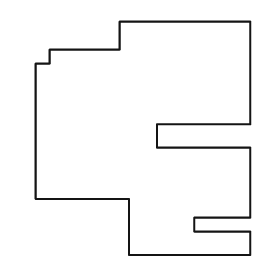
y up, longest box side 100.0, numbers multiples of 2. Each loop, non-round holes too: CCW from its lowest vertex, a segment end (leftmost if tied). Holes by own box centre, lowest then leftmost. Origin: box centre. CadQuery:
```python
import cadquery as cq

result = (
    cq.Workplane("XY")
    .moveTo(-6.0, -50.0)
    .lineTo(46.0, -50.0)
    .lineTo(46.0, -40.0)
    .lineTo(22.0, -40.0)
    .lineTo(22.0, -34.0)
    .lineTo(46.0, -34.0)
    .lineTo(46.0, -4.0)
    .lineTo(6.0, -4.0)
    .lineTo(6.0, 6.0)
    .lineTo(46.0, 6.0)
    .lineTo(46.0, 50.0)
    .lineTo(-10.0, 50.0)
    .lineTo(-10.0, 38.0)
    .lineTo(-40.0, 38.0)
    .lineTo(-40.0, 32.0)
    .lineTo(-46.0, 32.0)
    .lineTo(-46.0, -26.0)
    .lineTo(-6.0, -26.0)
    .close()
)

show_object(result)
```